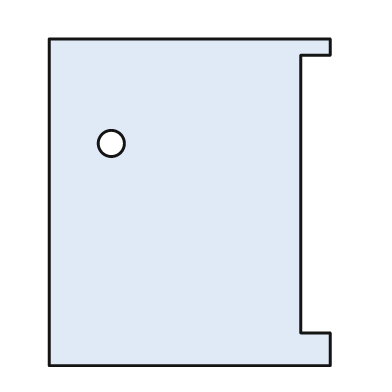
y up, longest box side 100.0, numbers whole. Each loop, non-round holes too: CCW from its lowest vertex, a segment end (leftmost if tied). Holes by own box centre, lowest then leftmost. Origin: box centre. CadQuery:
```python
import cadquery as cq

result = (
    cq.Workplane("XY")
    .moveTo(-43.0, -50.0)
    .lineTo(43.0, -50.0)
    .lineTo(43.0, -40.0)
    .lineTo(34.0, -40.0)
    .lineTo(34.0, 45.0)
    .lineTo(43.0, 45.0)
    .lineTo(43.0, 50.0)
    .lineTo(-43.0, 50.0)
    .close()
    .moveTo(-24.0, 18.0)
    .circle(4.0)
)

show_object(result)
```